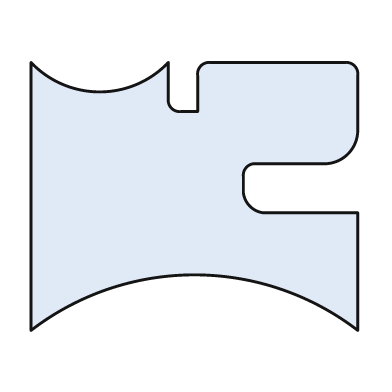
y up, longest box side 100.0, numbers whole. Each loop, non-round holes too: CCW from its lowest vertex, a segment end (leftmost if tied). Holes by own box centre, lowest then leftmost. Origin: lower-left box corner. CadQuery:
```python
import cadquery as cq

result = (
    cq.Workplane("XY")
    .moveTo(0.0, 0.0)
    .threePointArc((50.0, 17.0), (100.0, 0.0))
    .lineTo(100.0, 36.0)
    .lineTo(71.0, 36.0)
    .threePointArc((67.0, 38.0), (65.0, 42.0))
    .lineTo(65.0, 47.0)
    .threePointArc((66.0, 50.0), (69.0, 51.0))
    .lineTo(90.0, 51.0)
    .threePointArc((97.0, 54.0), (100.0, 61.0))
    .lineTo(100.0, 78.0)
    .threePointArc((99.0, 81.0), (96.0, 82.0))
    .lineTo(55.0, 82.0)
    .threePointArc((52.0, 81.0), (51.0, 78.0))
    .lineTo(51.0, 67.0)
    .lineTo(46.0, 67.0)
    .threePointArc((43.0, 68.0), (42.0, 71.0))
    .lineTo(42.0, 82.0)
    .threePointArc((21.0, 73.0), (0.0, 82.0))
    .close()
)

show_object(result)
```